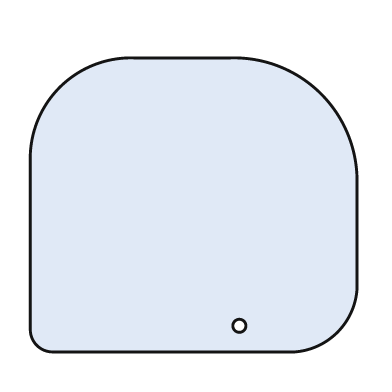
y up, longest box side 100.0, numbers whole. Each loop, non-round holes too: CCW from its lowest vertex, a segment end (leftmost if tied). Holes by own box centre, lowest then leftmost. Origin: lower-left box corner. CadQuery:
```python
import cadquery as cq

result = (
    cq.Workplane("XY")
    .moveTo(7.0, 0.0)
    .lineTo(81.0, 0.0)
    .threePointArc((94.0, 6.0), (100.0, 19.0))
    .lineTo(100.0, 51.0)
    .threePointArc((89.0, 79.0), (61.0, 90.0))
    .lineTo(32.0, 90.0)
    .threePointArc((9.0, 81.0), (0.0, 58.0))
    .lineTo(0.0, 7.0)
    .threePointArc((2.0, 2.0), (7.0, 0.0))
    .close()
    .moveTo(64.0, 8.0)
    .circle(2.0)
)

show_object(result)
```